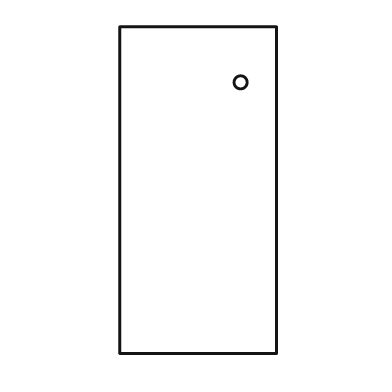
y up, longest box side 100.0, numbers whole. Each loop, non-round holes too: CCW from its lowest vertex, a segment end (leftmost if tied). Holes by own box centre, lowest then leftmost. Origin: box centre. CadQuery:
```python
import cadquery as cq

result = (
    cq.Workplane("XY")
    .moveTo(-24.0, -50.0)
    .lineTo(24.0, -50.0)
    .lineTo(24.0, 50.0)
    .lineTo(-24.0, 50.0)
    .close()
    .moveTo(13.0, 33.0)
    .circle(2.0)
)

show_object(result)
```